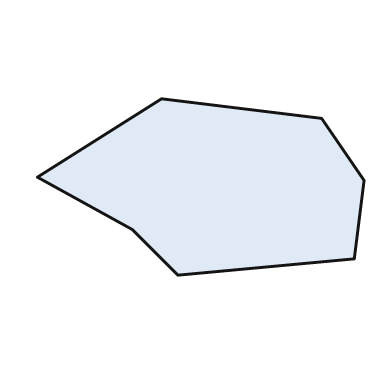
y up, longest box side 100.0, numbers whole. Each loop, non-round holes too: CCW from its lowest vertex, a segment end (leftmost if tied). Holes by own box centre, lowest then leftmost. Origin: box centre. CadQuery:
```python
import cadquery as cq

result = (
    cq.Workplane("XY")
    .moveTo(-7.0, -27.0)
    .lineTo(47.0, -22.0)
    .lineTo(50.0, 2.0)
    .lineTo(37.0, 21.0)
    .lineTo(-12.0, 27.0)
    .lineTo(-50.0, 3.0)
    .lineTo(-21.0, -13.0)
    .close()
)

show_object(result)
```